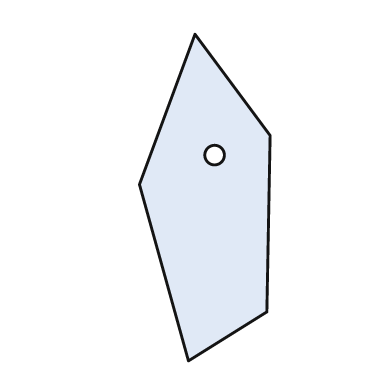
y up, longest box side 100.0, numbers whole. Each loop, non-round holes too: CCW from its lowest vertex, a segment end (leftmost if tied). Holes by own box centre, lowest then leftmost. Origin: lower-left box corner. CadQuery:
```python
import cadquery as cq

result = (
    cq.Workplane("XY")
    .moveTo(15.0, 0.0)
    .lineTo(39.0, 15.0)
    .lineTo(40.0, 69.0)
    .lineTo(17.0, 100.0)
    .lineTo(0.0, 54.0)
    .close()
    .moveTo(23.0, 63.0)
    .circle(3.0)
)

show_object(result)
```